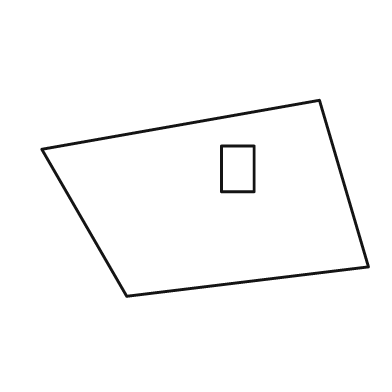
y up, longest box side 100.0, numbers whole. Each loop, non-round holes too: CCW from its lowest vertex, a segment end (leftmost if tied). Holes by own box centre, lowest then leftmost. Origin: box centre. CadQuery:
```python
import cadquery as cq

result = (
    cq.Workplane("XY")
    .moveTo(-24.0, -30.0)
    .lineTo(50.0, -21.0)
    .lineTo(35.0, 30.0)
    .lineTo(-50.0, 15.0)
    .close()
    .moveTo(5.0, 2.0)
    .lineTo(15.0, 2.0)
    .lineTo(15.0, 16.0)
    .lineTo(5.0, 16.0)
    .close()
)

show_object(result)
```